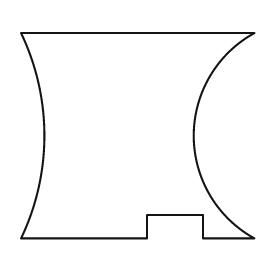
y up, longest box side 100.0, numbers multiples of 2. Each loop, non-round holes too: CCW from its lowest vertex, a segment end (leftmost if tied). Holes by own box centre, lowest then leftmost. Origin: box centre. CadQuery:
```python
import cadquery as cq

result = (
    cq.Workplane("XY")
    .moveTo(-50.0, -44.0)
    .lineTo(4.0, -44.0)
    .lineTo(4.0, -34.0)
    .lineTo(28.0, -34.0)
    .lineTo(28.0, -44.0)
    .lineTo(50.0, -44.0)
    .threePointArc((24.0, 0.0), (50.0, 44.0))
    .lineTo(-50.0, 44.0)
    .threePointArc((-40.0, 0.0), (-50.0, -44.0))
    .close()
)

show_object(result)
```